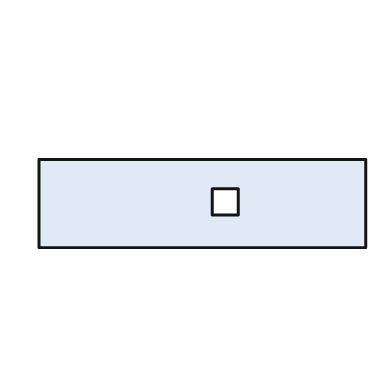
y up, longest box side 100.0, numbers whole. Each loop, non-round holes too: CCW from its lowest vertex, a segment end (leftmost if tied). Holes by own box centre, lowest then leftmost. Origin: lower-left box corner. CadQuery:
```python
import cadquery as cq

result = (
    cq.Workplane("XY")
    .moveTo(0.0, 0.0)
    .lineTo(100.0, 0.0)
    .lineTo(100.0, 27.0)
    .lineTo(0.0, 27.0)
    .close()
    .moveTo(53.0, 10.0)
    .lineTo(61.0, 10.0)
    .lineTo(61.0, 18.0)
    .lineTo(53.0, 18.0)
    .close()
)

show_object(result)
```